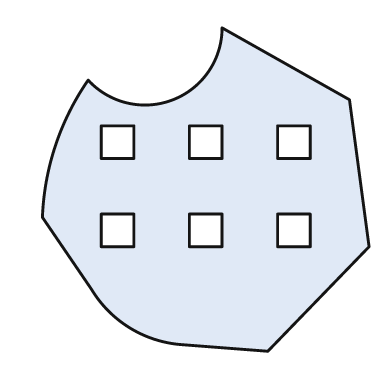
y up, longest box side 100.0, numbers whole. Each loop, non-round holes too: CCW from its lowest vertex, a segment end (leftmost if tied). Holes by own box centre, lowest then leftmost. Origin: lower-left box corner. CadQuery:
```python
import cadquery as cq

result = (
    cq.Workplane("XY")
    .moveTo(69.0, 0.0)
    .lineTo(100.0, 32.0)
    .lineTo(94.0, 77.0)
    .lineTo(55.0, 99.0)
    .threePointArc((40.0, 77.0), (14.0, 83.0))
    .threePointArc((4.0, 63.0), (0.0, 41.0))
    .lineTo(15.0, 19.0)
    .threePointArc((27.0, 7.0), (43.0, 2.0))
    .close()
    .moveTo(18.0, 32.0)
    .lineTo(28.0, 32.0)
    .lineTo(28.0, 42.0)
    .lineTo(18.0, 42.0)
    .close()
    .moveTo(45.0, 32.0)
    .lineTo(55.0, 32.0)
    .lineTo(55.0, 42.0)
    .lineTo(45.0, 42.0)
    .close()
    .moveTo(72.0, 32.0)
    .lineTo(82.0, 32.0)
    .lineTo(82.0, 42.0)
    .lineTo(72.0, 42.0)
    .close()
    .moveTo(18.0, 59.0)
    .lineTo(28.0, 59.0)
    .lineTo(28.0, 69.0)
    .lineTo(18.0, 69.0)
    .close()
    .moveTo(45.0, 59.0)
    .lineTo(55.0, 59.0)
    .lineTo(55.0, 69.0)
    .lineTo(45.0, 69.0)
    .close()
    .moveTo(72.0, 59.0)
    .lineTo(82.0, 59.0)
    .lineTo(82.0, 69.0)
    .lineTo(72.0, 69.0)
    .close()
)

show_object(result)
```